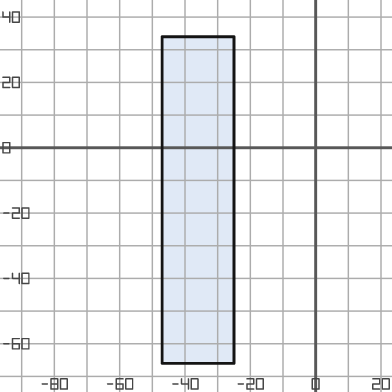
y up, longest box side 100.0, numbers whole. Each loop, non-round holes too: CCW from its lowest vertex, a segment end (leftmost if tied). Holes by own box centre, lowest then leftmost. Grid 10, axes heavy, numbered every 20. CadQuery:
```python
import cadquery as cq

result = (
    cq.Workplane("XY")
    .moveTo(-47.0, -66.0)
    .lineTo(-25.0, -66.0)
    .lineTo(-25.0, 34.0)
    .lineTo(-47.0, 34.0)
    .close()
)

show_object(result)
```